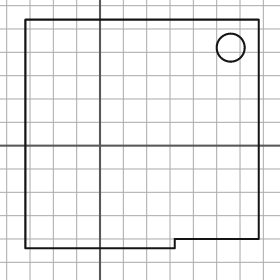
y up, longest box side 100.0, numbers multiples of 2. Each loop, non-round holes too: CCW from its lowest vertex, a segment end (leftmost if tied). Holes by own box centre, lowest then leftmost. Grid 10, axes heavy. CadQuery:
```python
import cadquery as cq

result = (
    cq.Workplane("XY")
    .moveTo(-32.0, -44.0)
    .lineTo(32.0, -44.0)
    .lineTo(32.0, -40.0)
    .lineTo(68.0, -40.0)
    .lineTo(68.0, 54.0)
    .lineTo(-32.0, 54.0)
    .close()
    .moveTo(56.0, 42.0)
    .circle(6.0)
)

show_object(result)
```